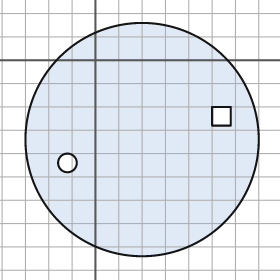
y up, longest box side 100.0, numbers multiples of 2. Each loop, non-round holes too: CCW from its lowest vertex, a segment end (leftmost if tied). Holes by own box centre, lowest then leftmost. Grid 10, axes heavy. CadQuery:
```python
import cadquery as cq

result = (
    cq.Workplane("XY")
    .moveTo(20.0, -34.0)
    .circle(50.0)
    .moveTo(-12.0, -44.0)
    .circle(4.0)
    .moveTo(50.0, -28.0)
    .lineTo(58.0, -28.0)
    .lineTo(58.0, -20.0)
    .lineTo(50.0, -20.0)
    .close()
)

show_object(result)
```